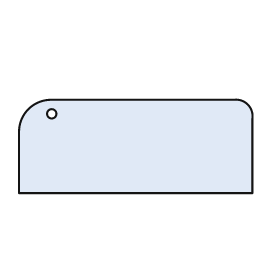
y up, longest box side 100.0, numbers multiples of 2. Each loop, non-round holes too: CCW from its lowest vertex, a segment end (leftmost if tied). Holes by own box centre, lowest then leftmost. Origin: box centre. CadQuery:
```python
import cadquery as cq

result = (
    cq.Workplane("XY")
    .moveTo(-50.0, -20.0)
    .lineTo(50.0, -20.0)
    .lineTo(50.0, 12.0)
    .threePointArc((48.0, 18.0), (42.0, 20.0))
    .lineTo(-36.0, 20.0)
    .threePointArc((-46.0, 16.0), (-50.0, 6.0))
    .close()
    .moveTo(-36.0, 14.0)
    .circle(2.0)
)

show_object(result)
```